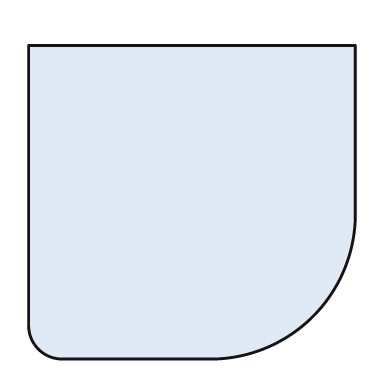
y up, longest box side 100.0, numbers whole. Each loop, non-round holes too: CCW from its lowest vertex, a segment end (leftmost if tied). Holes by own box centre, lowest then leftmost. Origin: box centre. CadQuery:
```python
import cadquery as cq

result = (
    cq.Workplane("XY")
    .moveTo(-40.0, -48.0)
    .lineTo(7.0, -48.0)
    .threePointArc((37.0, -35.0), (50.0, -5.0))
    .lineTo(50.0, 48.0)
    .lineTo(-50.0, 48.0)
    .lineTo(-50.0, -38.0)
    .threePointArc((-47.0, -45.0), (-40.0, -48.0))
    .close()
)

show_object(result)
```